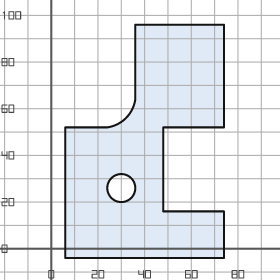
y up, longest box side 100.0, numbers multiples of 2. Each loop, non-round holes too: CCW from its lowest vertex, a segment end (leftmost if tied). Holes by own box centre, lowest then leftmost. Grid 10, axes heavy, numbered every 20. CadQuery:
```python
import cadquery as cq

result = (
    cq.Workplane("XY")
    .moveTo(6.0, -4.0)
    .lineTo(74.0, -4.0)
    .lineTo(74.0, 16.0)
    .lineTo(48.0, 16.0)
    .lineTo(48.0, 52.0)
    .lineTo(74.0, 52.0)
    .lineTo(74.0, 96.0)
    .lineTo(36.0, 96.0)
    .lineTo(36.0, 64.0)
    .threePointArc((32.0, 56.0), (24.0, 52.0))
    .lineTo(6.0, 52.0)
    .close()
    .moveTo(30.0, 26.0)
    .circle(6.0)
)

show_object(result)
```